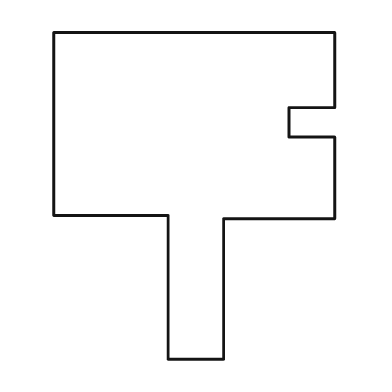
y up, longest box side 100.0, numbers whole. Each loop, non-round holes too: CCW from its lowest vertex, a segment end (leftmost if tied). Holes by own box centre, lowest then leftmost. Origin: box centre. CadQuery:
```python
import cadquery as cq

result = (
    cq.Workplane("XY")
    .moveTo(-8.0, -50.0)
    .lineTo(9.0, -50.0)
    .lineTo(9.0, -7.0)
    .lineTo(43.0, -7.0)
    .lineTo(43.0, 18.0)
    .lineTo(29.0, 18.0)
    .lineTo(29.0, 27.0)
    .lineTo(43.0, 27.0)
    .lineTo(43.0, 50.0)
    .lineTo(-43.0, 50.0)
    .lineTo(-43.0, -6.0)
    .lineTo(-8.0, -6.0)
    .close()
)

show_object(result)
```